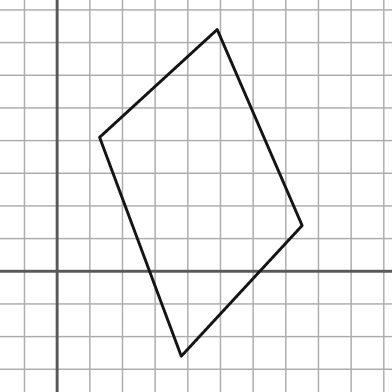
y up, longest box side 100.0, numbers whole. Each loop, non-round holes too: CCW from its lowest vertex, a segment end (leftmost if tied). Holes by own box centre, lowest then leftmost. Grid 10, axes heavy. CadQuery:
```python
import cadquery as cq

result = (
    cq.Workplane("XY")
    .moveTo(38.0, -26.0)
    .lineTo(75.0, 14.0)
    .lineTo(49.0, 74.0)
    .lineTo(13.0, 41.0)
    .close()
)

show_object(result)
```